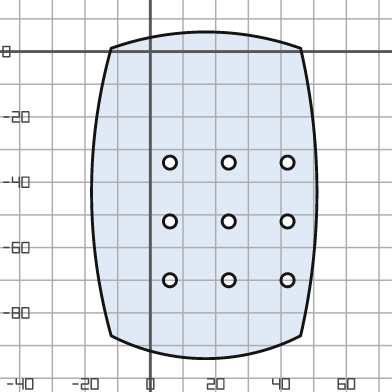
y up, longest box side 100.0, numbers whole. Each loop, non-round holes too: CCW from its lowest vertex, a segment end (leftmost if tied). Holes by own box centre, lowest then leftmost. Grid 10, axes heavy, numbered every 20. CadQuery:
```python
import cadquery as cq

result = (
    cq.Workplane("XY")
    .moveTo(-12.0, -87.0)
    .threePointArc((17.0, -94.0), (46.0, -87.0))
    .threePointArc((51.0, -43.0), (46.0, 1.0))
    .threePointArc((17.0, 6.0), (-12.0, 1.0))
    .threePointArc((-18.0, -43.0), (-12.0, -87.0))
    .close()
    .moveTo(6.0, -70.0)
    .circle(2.0)
    .moveTo(24.0, -70.0)
    .circle(2.0)
    .moveTo(42.0, -70.0)
    .circle(2.0)
    .moveTo(6.0, -52.0)
    .circle(2.0)
    .moveTo(24.0, -52.0)
    .circle(2.0)
    .moveTo(42.0, -52.0)
    .circle(2.0)
    .moveTo(6.0, -34.0)
    .circle(2.0)
    .moveTo(24.0, -34.0)
    .circle(2.0)
    .moveTo(42.0, -34.0)
    .circle(2.0)
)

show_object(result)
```